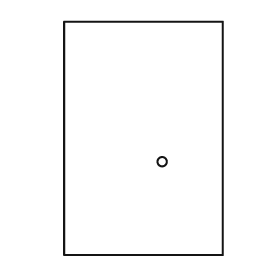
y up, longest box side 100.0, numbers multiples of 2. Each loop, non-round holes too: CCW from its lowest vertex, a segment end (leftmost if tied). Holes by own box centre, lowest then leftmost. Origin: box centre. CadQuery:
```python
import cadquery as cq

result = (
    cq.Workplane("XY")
    .moveTo(-34.0, -50.0)
    .lineTo(34.0, -50.0)
    .lineTo(34.0, 50.0)
    .lineTo(-34.0, 50.0)
    .close()
    .moveTo(8.0, -10.0)
    .circle(2.0)
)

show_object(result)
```